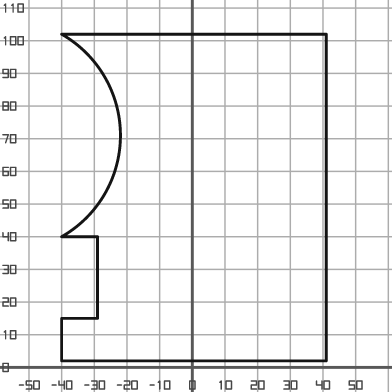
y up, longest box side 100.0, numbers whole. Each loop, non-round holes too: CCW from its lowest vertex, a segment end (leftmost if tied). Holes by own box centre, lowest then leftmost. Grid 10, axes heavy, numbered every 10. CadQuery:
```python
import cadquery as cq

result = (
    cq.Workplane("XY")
    .moveTo(-40.0, 2.0)
    .lineTo(41.0, 2.0)
    .lineTo(41.0, 102.0)
    .lineTo(-40.0, 102.0)
    .threePointArc((-22.0, 71.0), (-40.0, 40.0))
    .lineTo(-29.0, 40.0)
    .lineTo(-29.0, 15.0)
    .lineTo(-40.0, 15.0)
    .close()
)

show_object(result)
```